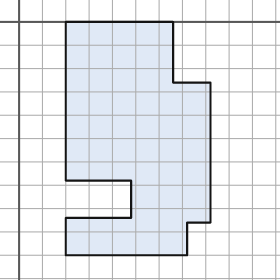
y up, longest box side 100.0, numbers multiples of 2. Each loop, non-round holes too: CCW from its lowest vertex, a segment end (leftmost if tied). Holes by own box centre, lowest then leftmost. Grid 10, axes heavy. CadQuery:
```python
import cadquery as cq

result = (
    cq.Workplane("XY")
    .moveTo(20.0, -100.0)
    .lineTo(72.0, -100.0)
    .lineTo(72.0, -86.0)
    .lineTo(82.0, -86.0)
    .lineTo(82.0, -26.0)
    .lineTo(66.0, -26.0)
    .lineTo(66.0, 0.0)
    .lineTo(20.0, 0.0)
    .lineTo(20.0, -68.0)
    .lineTo(48.0, -68.0)
    .lineTo(48.0, -84.0)
    .lineTo(20.0, -84.0)
    .close()
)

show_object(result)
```